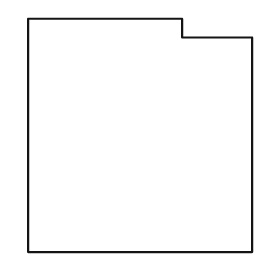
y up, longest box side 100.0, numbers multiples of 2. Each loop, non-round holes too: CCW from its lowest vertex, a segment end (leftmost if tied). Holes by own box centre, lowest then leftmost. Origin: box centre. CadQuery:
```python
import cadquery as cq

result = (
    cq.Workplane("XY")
    .moveTo(-48.0, -50.0)
    .lineTo(48.0, -50.0)
    .lineTo(48.0, 42.0)
    .lineTo(18.0, 42.0)
    .lineTo(18.0, 50.0)
    .lineTo(-48.0, 50.0)
    .close()
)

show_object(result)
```